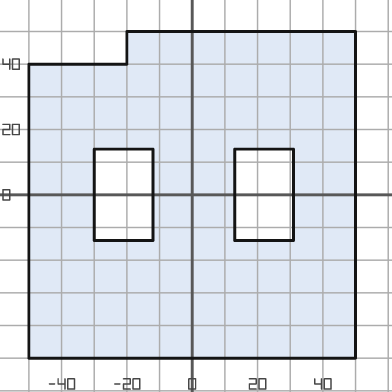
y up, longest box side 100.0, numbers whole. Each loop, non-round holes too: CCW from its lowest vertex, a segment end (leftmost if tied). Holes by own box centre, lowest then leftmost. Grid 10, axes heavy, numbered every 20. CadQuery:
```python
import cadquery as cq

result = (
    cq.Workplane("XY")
    .moveTo(-50.0, -50.0)
    .lineTo(50.0, -50.0)
    .lineTo(50.0, 50.0)
    .lineTo(-20.0, 50.0)
    .lineTo(-20.0, 40.0)
    .lineTo(-50.0, 40.0)
    .close()
    .moveTo(-30.0, -14.0)
    .lineTo(-12.0, -14.0)
    .lineTo(-12.0, 14.0)
    .lineTo(-30.0, 14.0)
    .close()
    .moveTo(13.0, -14.0)
    .lineTo(31.0, -14.0)
    .lineTo(31.0, 14.0)
    .lineTo(13.0, 14.0)
    .close()
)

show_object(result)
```